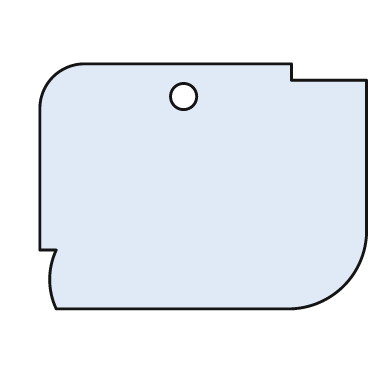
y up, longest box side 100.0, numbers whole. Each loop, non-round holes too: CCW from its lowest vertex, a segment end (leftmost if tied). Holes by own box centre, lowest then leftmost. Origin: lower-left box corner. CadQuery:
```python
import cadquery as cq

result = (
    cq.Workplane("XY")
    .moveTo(5.0, 0.0)
    .lineTo(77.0, 0.0)
    .threePointArc((93.0, 7.0), (100.0, 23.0))
    .lineTo(100.0, 70.0)
    .lineTo(77.0, 70.0)
    .lineTo(77.0, 75.0)
    .lineTo(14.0, 75.0)
    .threePointArc((4.0, 71.0), (0.0, 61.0))
    .lineTo(0.0, 18.0)
    .lineTo(5.0, 18.0)
    .threePointArc((3.0, 9.0), (5.0, 0.0))
    .close()
    .moveTo(44.0, 65.0)
    .circle(4.0)
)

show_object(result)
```